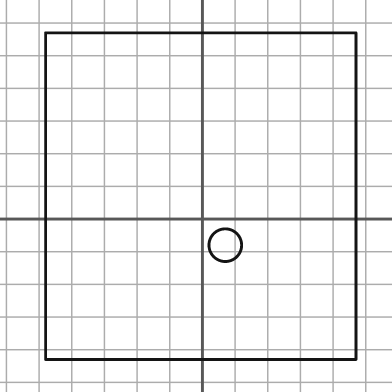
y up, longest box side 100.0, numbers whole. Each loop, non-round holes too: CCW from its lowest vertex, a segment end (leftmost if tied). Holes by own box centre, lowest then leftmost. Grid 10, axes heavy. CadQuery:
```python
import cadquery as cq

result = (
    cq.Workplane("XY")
    .moveTo(-48.0, -43.0)
    .lineTo(47.0, -43.0)
    .lineTo(47.0, 57.0)
    .lineTo(-48.0, 57.0)
    .close()
    .moveTo(7.0, -8.0)
    .circle(5.0)
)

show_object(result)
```